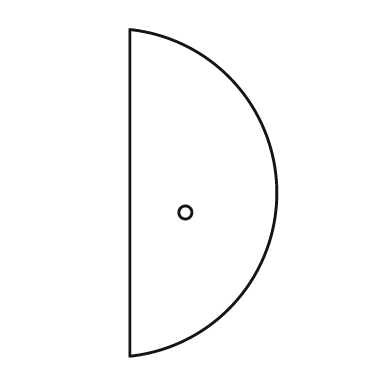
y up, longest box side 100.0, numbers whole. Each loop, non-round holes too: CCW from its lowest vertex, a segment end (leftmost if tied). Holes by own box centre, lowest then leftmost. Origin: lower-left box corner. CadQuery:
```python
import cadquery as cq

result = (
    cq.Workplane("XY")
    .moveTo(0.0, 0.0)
    .threePointArc((45.0, 50.0), (0.0, 100.0))
    .close()
    .moveTo(17.0, 44.0)
    .circle(2.0)
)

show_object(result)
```